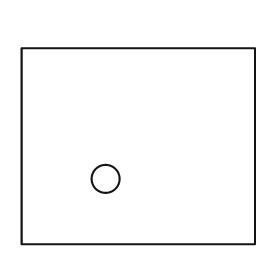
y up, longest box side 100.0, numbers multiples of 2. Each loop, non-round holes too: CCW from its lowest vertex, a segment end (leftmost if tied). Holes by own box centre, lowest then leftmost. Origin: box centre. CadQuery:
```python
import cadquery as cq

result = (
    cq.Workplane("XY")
    .moveTo(-50.0, -42.0)
    .lineTo(50.0, -42.0)
    .lineTo(50.0, 42.0)
    .lineTo(-50.0, 42.0)
    .close()
    .moveTo(-14.0, -14.0)
    .circle(6.0)
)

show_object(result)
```